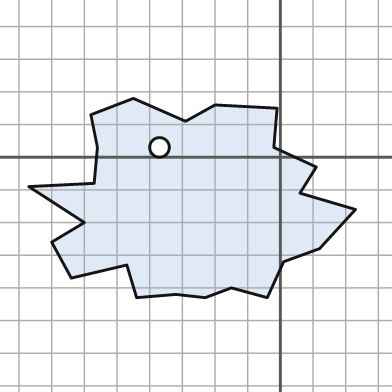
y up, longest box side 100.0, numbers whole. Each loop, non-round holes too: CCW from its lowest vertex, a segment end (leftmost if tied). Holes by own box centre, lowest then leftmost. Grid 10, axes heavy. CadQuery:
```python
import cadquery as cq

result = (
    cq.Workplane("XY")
    .moveTo(-44.0, -43.0)
    .lineTo(-32.0, -42.0)
    .lineTo(-23.0, -43.0)
    .lineTo(-15.0, -40.0)
    .lineTo(-4.0, -43.0)
    .lineTo(1.0, -32.0)
    .lineTo(12.0, -28.0)
    .lineTo(23.0, -16.0)
    .lineTo(6.0, -11.0)
    .lineTo(11.0, -3.0)
    .lineTo(-2.0, 3.0)
    .lineTo(-1.0, 15.0)
    .lineTo(-20.0, 16.0)
    .lineTo(-29.0, 11.0)
    .lineTo(-45.0, 18.0)
    .lineTo(-58.0, 13.0)
    .lineTo(-56.0, 3.0)
    .lineTo(-57.0, -8.0)
    .lineTo(-77.0, -9.0)
    .lineTo(-60.0, -20.0)
    .lineTo(-70.0, -26.0)
    .lineTo(-64.0, -37.0)
    .lineTo(-47.0, -33.0)
    .close()
    .moveTo(-37.0, 3.0)
    .circle(3.0)
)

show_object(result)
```